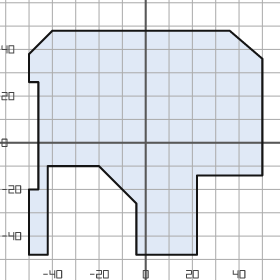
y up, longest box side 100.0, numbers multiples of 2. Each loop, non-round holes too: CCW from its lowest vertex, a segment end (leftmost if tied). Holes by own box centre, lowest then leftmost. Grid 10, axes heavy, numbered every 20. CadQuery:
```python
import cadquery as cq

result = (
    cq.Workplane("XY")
    .moveTo(-50.0, -48.0)
    .lineTo(-42.0, -48.0)
    .lineTo(-42.0, -10.0)
    .lineTo(-20.0, -10.0)
    .lineTo(-4.0, -26.0)
    .lineTo(-4.0, -48.0)
    .lineTo(22.0, -48.0)
    .lineTo(22.0, -14.0)
    .lineTo(50.0, -14.0)
    .lineTo(50.0, 36.0)
    .lineTo(36.0, 48.0)
    .lineTo(-40.0, 48.0)
    .lineTo(-50.0, 38.0)
    .lineTo(-50.0, 26.0)
    .lineTo(-46.0, 26.0)
    .lineTo(-46.0, -20.0)
    .lineTo(-50.0, -20.0)
    .close()
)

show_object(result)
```